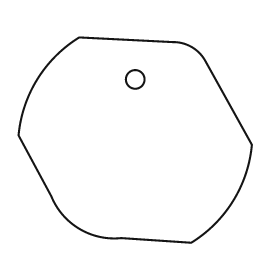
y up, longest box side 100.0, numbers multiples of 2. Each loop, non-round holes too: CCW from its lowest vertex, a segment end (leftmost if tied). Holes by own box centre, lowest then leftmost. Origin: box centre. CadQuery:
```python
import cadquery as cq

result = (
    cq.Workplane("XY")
    .moveTo(24.0, -44.0)
    .threePointArc((42.0, -26.0), (50.0, -2.0))
    .lineTo(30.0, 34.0)
    .threePointArc((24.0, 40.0), (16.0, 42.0))
    .lineTo(-24.0, 44.0)
    .threePointArc((-42.0, 26.0), (-50.0, 2.0))
    .lineTo(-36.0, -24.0)
    .threePointArc((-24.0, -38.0), (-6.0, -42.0))
    .close()
    .moveTo(0.0, 26.0)
    .circle(4.0)
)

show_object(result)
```